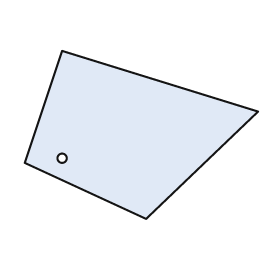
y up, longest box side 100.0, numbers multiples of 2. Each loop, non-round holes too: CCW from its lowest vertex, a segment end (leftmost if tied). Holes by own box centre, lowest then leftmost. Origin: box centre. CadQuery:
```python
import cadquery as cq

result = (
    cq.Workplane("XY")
    .moveTo(2.0, -36.0)
    .lineTo(50.0, 10.0)
    .lineTo(-34.0, 36.0)
    .lineTo(-50.0, -12.0)
    .close()
    .moveTo(-34.0, -10.0)
    .circle(2.0)
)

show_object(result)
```